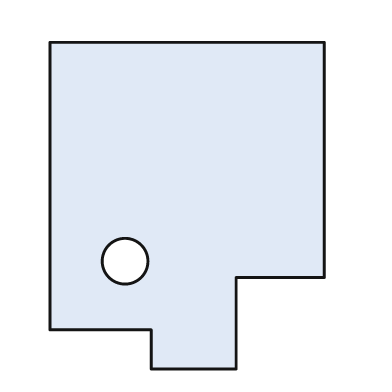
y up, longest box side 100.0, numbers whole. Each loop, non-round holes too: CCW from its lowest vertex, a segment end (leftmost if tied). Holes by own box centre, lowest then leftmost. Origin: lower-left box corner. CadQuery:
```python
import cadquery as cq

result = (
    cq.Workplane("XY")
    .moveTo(31.0, 0.0)
    .lineTo(57.0, 0.0)
    .lineTo(57.0, 28.0)
    .lineTo(84.0, 28.0)
    .lineTo(84.0, 100.0)
    .lineTo(0.0, 100.0)
    .lineTo(0.0, 12.0)
    .lineTo(31.0, 12.0)
    .close()
    .moveTo(23.0, 33.0)
    .circle(7.0)
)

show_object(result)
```